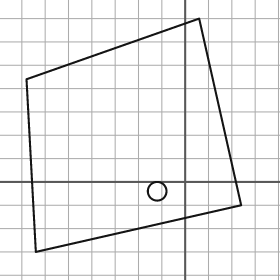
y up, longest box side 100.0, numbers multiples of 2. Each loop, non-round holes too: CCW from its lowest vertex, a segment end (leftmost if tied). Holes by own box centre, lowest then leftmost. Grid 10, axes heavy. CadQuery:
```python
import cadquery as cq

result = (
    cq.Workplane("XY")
    .moveTo(-64.0, -30.0)
    .lineTo(24.0, -10.0)
    .lineTo(6.0, 70.0)
    .lineTo(-68.0, 44.0)
    .close()
    .moveTo(-12.0, -4.0)
    .circle(4.0)
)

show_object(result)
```